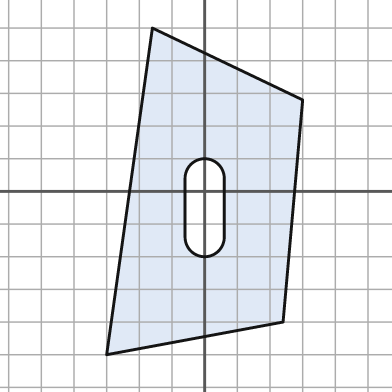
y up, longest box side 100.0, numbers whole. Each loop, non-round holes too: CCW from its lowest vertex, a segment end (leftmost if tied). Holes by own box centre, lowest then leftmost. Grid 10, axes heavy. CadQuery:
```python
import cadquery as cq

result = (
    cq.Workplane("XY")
    .moveTo(-30.0, -50.0)
    .lineTo(24.0, -40.0)
    .lineTo(30.0, 28.0)
    .lineTo(-16.0, 50.0)
    .close()
    .moveTo(-6.0, -14.0)
    .threePointArc((0.0, -20.0), (6.0, -14.0))
    .lineTo(6.0, 4.0)
    .threePointArc((0.0, 10.0), (-6.0, 4.0))
    .close()
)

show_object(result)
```